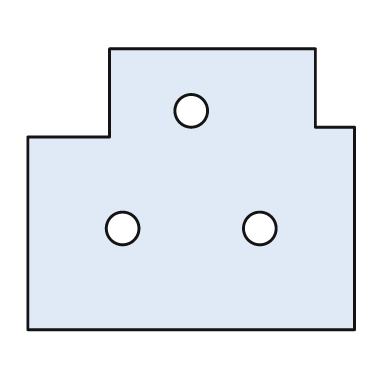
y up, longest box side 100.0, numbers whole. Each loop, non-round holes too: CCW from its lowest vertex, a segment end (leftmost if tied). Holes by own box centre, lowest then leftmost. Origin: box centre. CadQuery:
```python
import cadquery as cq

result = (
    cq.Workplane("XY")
    .moveTo(-50.0, -43.0)
    .lineTo(50.0, -43.0)
    .lineTo(50.0, 19.0)
    .lineTo(38.0, 19.0)
    .lineTo(38.0, 43.0)
    .lineTo(-25.0, 43.0)
    .lineTo(-25.0, 16.0)
    .lineTo(-50.0, 16.0)
    .close()
    .moveTo(-21.0, -12.0)
    .circle(5.0)
    .moveTo(21.0, -12.0)
    .circle(5.0)
    .moveTo(0.0, 24.0)
    .circle(5.0)
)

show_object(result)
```